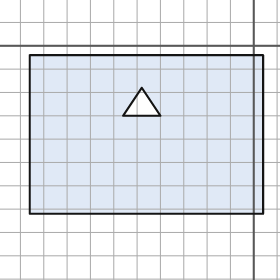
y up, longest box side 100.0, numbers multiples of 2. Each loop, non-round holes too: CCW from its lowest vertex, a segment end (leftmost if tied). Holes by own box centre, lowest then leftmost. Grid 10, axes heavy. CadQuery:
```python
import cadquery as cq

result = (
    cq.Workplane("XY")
    .moveTo(-96.0, -72.0)
    .lineTo(4.0, -72.0)
    .lineTo(4.0, -4.0)
    .lineTo(-96.0, -4.0)
    .close()
    .moveTo(-56.0, -30.0)
    .lineTo(-40.0, -30.0)
    .lineTo(-48.0, -18.0)
    .close()
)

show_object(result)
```